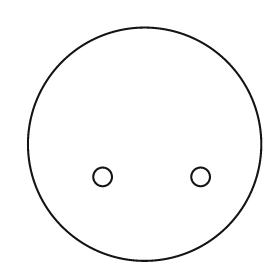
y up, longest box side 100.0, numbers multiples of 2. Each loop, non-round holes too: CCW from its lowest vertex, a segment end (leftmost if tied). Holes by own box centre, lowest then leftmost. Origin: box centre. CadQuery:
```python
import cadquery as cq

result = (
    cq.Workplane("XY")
    .moveTo(0.0, 0.0)
    .circle(50.0)
    .moveTo(-18.0, -14.0)
    .circle(4.0)
    .moveTo(24.0, -14.0)
    .circle(4.0)
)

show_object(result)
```